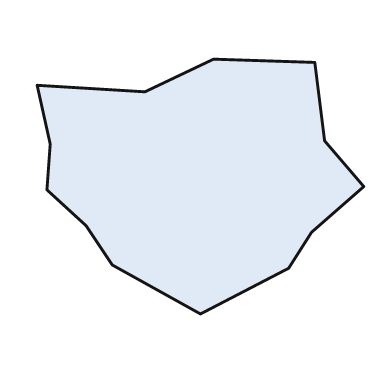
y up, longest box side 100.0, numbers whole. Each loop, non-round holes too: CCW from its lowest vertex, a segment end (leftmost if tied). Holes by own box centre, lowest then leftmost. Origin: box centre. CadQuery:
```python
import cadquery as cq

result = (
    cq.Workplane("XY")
    .moveTo(0.0, -39.0)
    .lineTo(27.0, -25.0)
    .lineTo(34.0, -14.0)
    .lineTo(50.0, 0.0)
    .lineTo(38.0, 14.0)
    .lineTo(35.0, 38.0)
    .lineTo(4.0, 39.0)
    .lineTo(-17.0, 29.0)
    .lineTo(-50.0, 31.0)
    .lineTo(-46.0, 13.0)
    .lineTo(-47.0, -1.0)
    .lineTo(-35.0, -12.0)
    .lineTo(-27.0, -24.0)
    .close()
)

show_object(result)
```